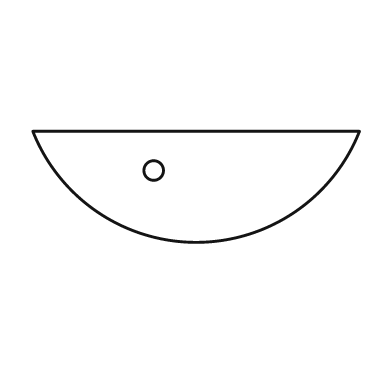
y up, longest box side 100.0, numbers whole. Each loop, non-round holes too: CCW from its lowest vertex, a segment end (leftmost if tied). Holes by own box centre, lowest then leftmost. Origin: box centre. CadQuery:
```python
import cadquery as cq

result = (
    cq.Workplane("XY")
    .moveTo(-50.0, 17.0)
    .threePointArc((0.0, -17.0), (50.0, 17.0))
    .close()
    .moveTo(-13.0, 5.0)
    .circle(3.0)
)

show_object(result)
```